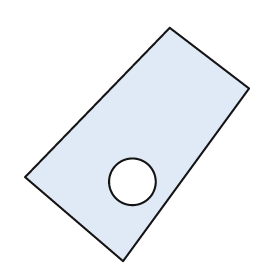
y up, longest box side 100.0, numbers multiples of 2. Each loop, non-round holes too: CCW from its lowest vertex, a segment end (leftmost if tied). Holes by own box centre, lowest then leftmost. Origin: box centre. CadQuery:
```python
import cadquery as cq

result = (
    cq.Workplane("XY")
    .moveTo(-6.0, -50.0)
    .lineTo(48.0, 24.0)
    .lineTo(14.0, 50.0)
    .lineTo(-48.0, -14.0)
    .close()
    .moveTo(-2.0, -16.0)
    .circle(10.0)
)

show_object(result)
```